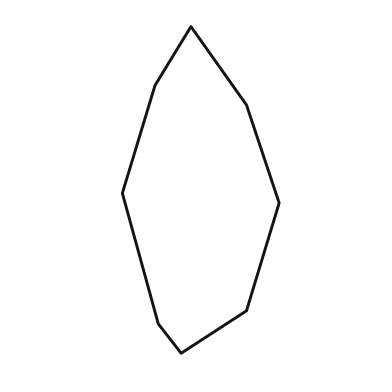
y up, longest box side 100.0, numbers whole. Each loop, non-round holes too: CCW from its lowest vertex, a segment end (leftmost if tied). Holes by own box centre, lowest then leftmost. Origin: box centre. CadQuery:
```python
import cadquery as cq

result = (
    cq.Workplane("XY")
    .moveTo(-6.0, -50.0)
    .lineTo(14.0, -37.0)
    .lineTo(24.0, -4.0)
    .lineTo(14.0, 26.0)
    .lineTo(-3.0, 50.0)
    .lineTo(-14.0, 32.0)
    .lineTo(-24.0, -1.0)
    .lineTo(-13.0, -41.0)
    .close()
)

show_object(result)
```